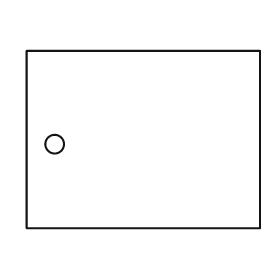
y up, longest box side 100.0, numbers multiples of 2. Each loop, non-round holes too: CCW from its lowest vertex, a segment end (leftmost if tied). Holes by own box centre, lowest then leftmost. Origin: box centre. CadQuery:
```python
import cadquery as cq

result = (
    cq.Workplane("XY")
    .moveTo(-50.0, -38.0)
    .lineTo(50.0, -38.0)
    .lineTo(50.0, 38.0)
    .lineTo(-50.0, 38.0)
    .close()
    .moveTo(-38.0, -2.0)
    .circle(4.0)
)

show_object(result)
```